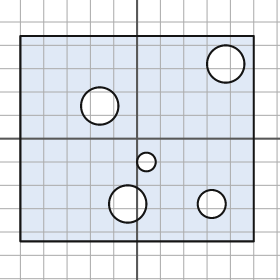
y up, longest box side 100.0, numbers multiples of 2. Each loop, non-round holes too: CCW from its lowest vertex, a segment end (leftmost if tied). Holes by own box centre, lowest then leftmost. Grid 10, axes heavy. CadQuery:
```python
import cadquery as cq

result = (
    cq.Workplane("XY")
    .moveTo(-50.0, -44.0)
    .lineTo(50.0, -44.0)
    .lineTo(50.0, 44.0)
    .lineTo(-50.0, 44.0)
    .close()
    .moveTo(-4.0, -28.0)
    .circle(8.0)
    .moveTo(32.0, -28.0)
    .circle(6.0)
    .moveTo(4.0, -10.0)
    .circle(4.0)
    .moveTo(-16.0, 14.0)
    .circle(8.0)
    .moveTo(38.0, 32.0)
    .circle(8.0)
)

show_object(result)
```